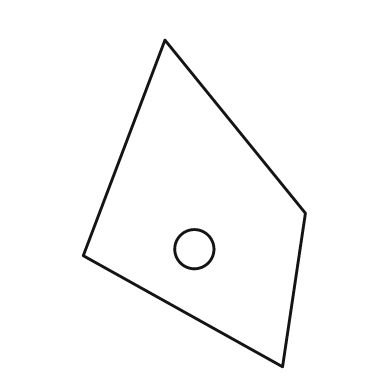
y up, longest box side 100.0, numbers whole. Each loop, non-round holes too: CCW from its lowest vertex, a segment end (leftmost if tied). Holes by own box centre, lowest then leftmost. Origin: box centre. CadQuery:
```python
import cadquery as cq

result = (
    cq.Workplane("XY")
    .moveTo(27.0, -50.0)
    .lineTo(34.0, -3.0)
    .lineTo(-9.0, 50.0)
    .lineTo(-34.0, -16.0)
    .close()
    .moveTo(0.0, -14.0)
    .circle(6.0)
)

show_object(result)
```